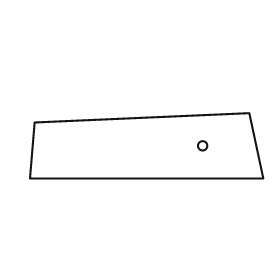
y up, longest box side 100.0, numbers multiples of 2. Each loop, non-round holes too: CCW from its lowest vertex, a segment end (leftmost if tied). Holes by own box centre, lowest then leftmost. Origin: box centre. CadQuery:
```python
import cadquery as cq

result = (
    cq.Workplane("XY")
    .moveTo(-50.0, -14.0)
    .lineTo(50.0, -14.0)
    .lineTo(44.0, 14.0)
    .lineTo(-48.0, 10.0)
    .close()
    .moveTo(24.0, 0.0)
    .circle(2.0)
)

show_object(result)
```